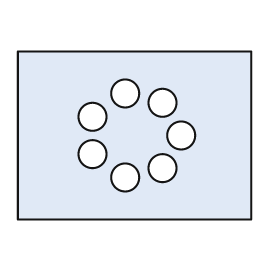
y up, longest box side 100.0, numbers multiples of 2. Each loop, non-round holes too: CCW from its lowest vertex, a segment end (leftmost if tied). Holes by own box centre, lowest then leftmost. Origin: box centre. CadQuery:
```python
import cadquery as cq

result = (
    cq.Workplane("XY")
    .moveTo(-50.0, -36.0)
    .lineTo(50.0, -36.0)
    .lineTo(50.0, 36.0)
    .lineTo(-50.0, 36.0)
    .close()
    .moveTo(-4.0, -18.0)
    .circle(6.0)
    .moveTo(12.0, -14.0)
    .circle(6.0)
    .moveTo(-18.0, -8.0)
    .circle(6.0)
    .moveTo(20.0, 0.0)
    .circle(6.0)
    .moveTo(-18.0, 8.0)
    .circle(6.0)
    .moveTo(12.0, 14.0)
    .circle(6.0)
    .moveTo(-4.0, 18.0)
    .circle(6.0)
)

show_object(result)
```